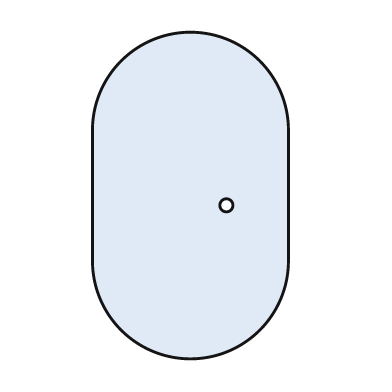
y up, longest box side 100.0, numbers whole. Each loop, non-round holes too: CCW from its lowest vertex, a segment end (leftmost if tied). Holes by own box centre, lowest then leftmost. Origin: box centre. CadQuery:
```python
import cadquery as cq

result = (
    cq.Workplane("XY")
    .moveTo(-30.0, -20.0)
    .threePointArc((0.0, -50.0), (30.0, -20.0))
    .lineTo(30.0, 20.0)
    .threePointArc((0.0, 50.0), (-30.0, 20.0))
    .close()
    .moveTo(11.0, -3.0)
    .circle(2.0)
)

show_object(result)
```